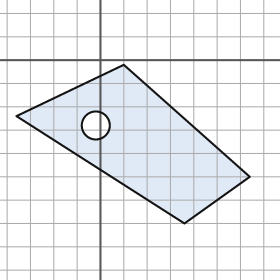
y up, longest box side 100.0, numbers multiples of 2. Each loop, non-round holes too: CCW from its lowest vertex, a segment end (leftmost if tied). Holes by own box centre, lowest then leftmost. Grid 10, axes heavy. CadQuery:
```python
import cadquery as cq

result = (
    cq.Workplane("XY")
    .moveTo(36.0, -70.0)
    .lineTo(64.0, -50.0)
    .lineTo(10.0, -2.0)
    .lineTo(-36.0, -24.0)
    .close()
    .moveTo(-2.0, -28.0)
    .circle(6.0)
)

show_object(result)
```